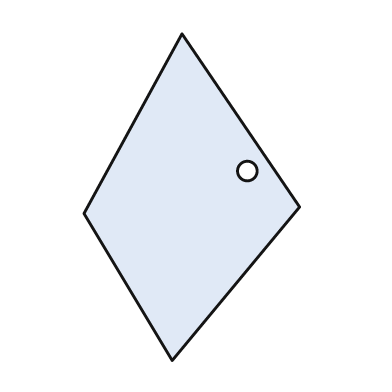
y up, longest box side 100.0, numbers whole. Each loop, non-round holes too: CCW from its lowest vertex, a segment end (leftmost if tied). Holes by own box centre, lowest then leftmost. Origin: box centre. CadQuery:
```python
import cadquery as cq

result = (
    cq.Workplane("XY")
    .moveTo(-6.0, -50.0)
    .lineTo(33.0, -3.0)
    .lineTo(-3.0, 50.0)
    .lineTo(-33.0, -5.0)
    .close()
    .moveTo(17.0, 8.0)
    .circle(3.0)
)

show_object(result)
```